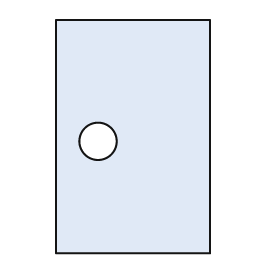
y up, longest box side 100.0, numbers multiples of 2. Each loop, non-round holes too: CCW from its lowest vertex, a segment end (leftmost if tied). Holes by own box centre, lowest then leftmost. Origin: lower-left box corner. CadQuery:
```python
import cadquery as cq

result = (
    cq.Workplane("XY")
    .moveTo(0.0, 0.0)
    .lineTo(66.0, 0.0)
    .lineTo(66.0, 100.0)
    .lineTo(0.0, 100.0)
    .close()
    .moveTo(18.0, 48.0)
    .circle(8.0)
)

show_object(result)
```